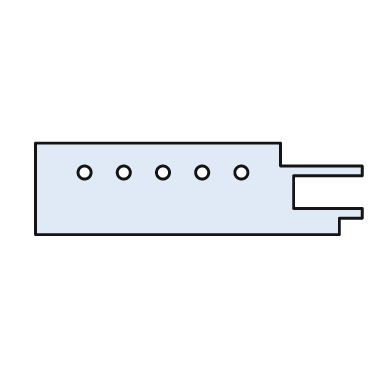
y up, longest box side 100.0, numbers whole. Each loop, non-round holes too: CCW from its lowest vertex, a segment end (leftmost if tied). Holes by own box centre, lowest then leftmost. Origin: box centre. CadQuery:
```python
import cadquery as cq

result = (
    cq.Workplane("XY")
    .moveTo(-50.0, -14.0)
    .lineTo(43.0, -14.0)
    .lineTo(43.0, -9.0)
    .lineTo(50.0, -9.0)
    .lineTo(50.0, -6.0)
    .lineTo(29.0, -6.0)
    .lineTo(29.0, 4.0)
    .lineTo(50.0, 4.0)
    .lineTo(50.0, 7.0)
    .lineTo(25.0, 7.0)
    .lineTo(25.0, 14.0)
    .lineTo(-50.0, 14.0)
    .close()
    .moveTo(-35.0, 5.0)
    .circle(2.0)
    .moveTo(-23.0, 5.0)
    .circle(2.0)
    .moveTo(-11.0, 5.0)
    .circle(2.0)
    .moveTo(1.0, 5.0)
    .circle(2.0)
    .moveTo(13.0, 5.0)
    .circle(2.0)
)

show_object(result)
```